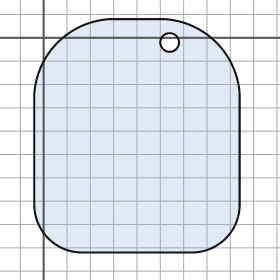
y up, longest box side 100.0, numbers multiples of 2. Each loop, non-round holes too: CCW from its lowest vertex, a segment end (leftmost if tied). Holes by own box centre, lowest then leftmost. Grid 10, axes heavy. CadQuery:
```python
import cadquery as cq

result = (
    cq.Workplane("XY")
    .moveTo(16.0, -92.0)
    .lineTo(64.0, -92.0)
    .threePointArc((78.0, -86.0), (84.0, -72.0))
    .lineTo(84.0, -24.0)
    .threePointArc((74.0, -2.0), (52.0, 8.0))
    .lineTo(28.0, 8.0)
    .threePointArc((6.0, -2.0), (-4.0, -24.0))
    .lineTo(-4.0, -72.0)
    .threePointArc((2.0, -86.0), (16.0, -92.0))
    .close()
    .moveTo(54.0, -2.0)
    .circle(4.0)
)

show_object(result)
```